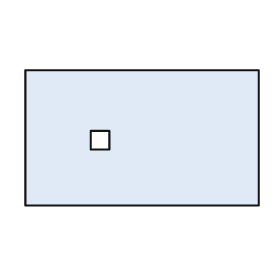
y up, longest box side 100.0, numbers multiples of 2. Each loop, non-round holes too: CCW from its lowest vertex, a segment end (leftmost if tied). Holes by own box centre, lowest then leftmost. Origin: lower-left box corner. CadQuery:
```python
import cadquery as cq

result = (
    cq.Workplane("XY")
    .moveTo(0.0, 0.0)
    .lineTo(100.0, 0.0)
    .lineTo(100.0, 58.0)
    .lineTo(0.0, 58.0)
    .close()
    .moveTo(28.0, 24.0)
    .lineTo(36.0, 24.0)
    .lineTo(36.0, 32.0)
    .lineTo(28.0, 32.0)
    .close()
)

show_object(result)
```